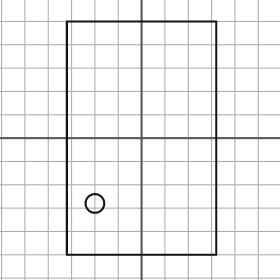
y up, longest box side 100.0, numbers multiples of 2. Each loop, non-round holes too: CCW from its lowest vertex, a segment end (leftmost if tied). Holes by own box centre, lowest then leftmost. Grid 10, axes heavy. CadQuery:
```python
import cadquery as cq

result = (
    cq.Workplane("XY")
    .moveTo(-32.0, -50.0)
    .lineTo(32.0, -50.0)
    .lineTo(32.0, 50.0)
    .lineTo(-32.0, 50.0)
    .close()
    .moveTo(-20.0, -28.0)
    .circle(4.0)
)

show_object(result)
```